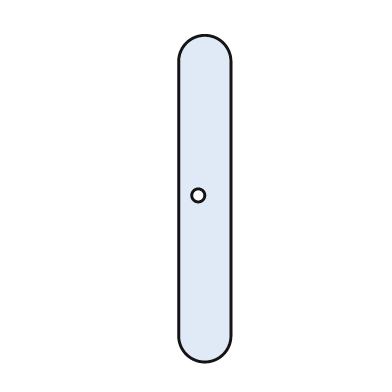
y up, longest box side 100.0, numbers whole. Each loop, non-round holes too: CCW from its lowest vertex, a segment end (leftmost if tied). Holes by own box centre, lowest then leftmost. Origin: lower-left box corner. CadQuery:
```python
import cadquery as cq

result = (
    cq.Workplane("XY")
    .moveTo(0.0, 8.0)
    .threePointArc((8.0, 0.0), (16.0, 8.0))
    .lineTo(16.0, 92.0)
    .threePointArc((8.0, 100.0), (0.0, 92.0))
    .close()
    .moveTo(6.0, 51.0)
    .circle(2.0)
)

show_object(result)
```